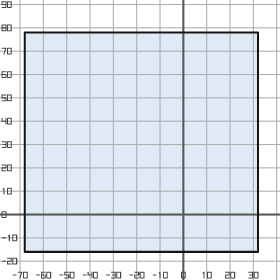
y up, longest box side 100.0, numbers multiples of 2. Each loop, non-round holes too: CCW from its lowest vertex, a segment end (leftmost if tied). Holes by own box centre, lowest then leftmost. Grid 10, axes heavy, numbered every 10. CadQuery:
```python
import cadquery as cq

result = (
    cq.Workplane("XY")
    .moveTo(-68.0, -16.0)
    .lineTo(32.0, -16.0)
    .lineTo(32.0, 78.0)
    .lineTo(-68.0, 78.0)
    .close()
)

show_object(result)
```